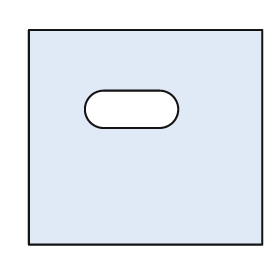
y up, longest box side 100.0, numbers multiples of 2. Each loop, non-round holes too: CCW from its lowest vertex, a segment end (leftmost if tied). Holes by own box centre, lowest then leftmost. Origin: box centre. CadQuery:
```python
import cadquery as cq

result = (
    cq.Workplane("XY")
    .moveTo(-50.0, -46.0)
    .lineTo(50.0, -46.0)
    .lineTo(50.0, 46.0)
    .lineTo(-50.0, 46.0)
    .close()
    .moveTo(-18.0, 4.0)
    .lineTo(6.0, 4.0)
    .threePointArc((14.0, 12.0), (6.0, 20.0))
    .lineTo(-18.0, 20.0)
    .threePointArc((-26.0, 12.0), (-18.0, 4.0))
    .close()
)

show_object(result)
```